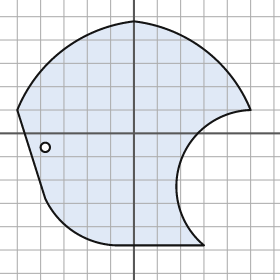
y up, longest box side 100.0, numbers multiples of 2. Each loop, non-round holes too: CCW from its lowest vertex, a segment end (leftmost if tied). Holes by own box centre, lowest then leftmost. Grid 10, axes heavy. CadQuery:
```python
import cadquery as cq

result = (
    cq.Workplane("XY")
    .moveTo(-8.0, -48.0)
    .lineTo(30.0, -48.0)
    .threePointArc((20.0, -12.0), (50.0, 10.0))
    .threePointArc((30.0, 36.0), (0.0, 48.0))
    .threePointArc((-30.0, 36.0), (-50.0, 10.0))
    .lineTo(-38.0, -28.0)
    .threePointArc((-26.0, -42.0), (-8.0, -48.0))
    .close()
    .moveTo(-38.0, -6.0)
    .circle(2.0)
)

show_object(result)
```